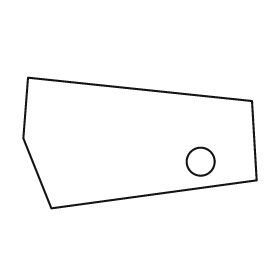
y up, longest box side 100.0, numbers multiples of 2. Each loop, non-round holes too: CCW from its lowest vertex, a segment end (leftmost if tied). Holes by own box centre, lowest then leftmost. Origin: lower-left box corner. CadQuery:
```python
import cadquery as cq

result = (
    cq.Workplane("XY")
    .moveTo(12.0, 0.0)
    .lineTo(100.0, 12.0)
    .lineTo(98.0, 46.0)
    .lineTo(2.0, 56.0)
    .lineTo(0.0, 30.0)
    .close()
    .moveTo(76.0, 20.0)
    .circle(6.0)
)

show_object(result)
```